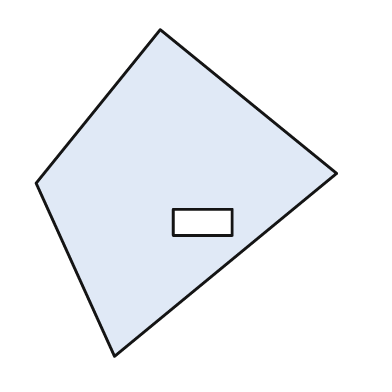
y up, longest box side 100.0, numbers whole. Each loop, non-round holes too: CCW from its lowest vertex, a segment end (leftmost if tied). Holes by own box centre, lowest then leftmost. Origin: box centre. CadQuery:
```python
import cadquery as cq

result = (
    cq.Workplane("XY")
    .moveTo(-22.0, -50.0)
    .lineTo(46.0, 6.0)
    .lineTo(-8.0, 50.0)
    .lineTo(-46.0, 3.0)
    .close()
    .moveTo(-4.0, -13.0)
    .lineTo(14.0, -13.0)
    .lineTo(14.0, -5.0)
    .lineTo(-4.0, -5.0)
    .close()
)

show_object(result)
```